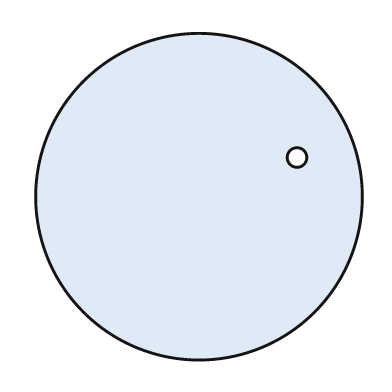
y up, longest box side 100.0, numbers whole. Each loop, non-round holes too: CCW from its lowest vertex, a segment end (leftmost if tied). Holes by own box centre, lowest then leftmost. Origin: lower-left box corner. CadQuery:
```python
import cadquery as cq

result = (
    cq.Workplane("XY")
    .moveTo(50.0, 50.0)
    .circle(50.0)
    .moveTo(80.0, 62.0)
    .circle(3.0)
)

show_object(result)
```